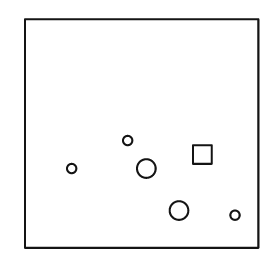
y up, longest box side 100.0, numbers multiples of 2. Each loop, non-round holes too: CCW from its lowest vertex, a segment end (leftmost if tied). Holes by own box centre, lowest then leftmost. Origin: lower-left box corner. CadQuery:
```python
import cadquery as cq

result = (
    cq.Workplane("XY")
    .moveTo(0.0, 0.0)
    .lineTo(100.0, 0.0)
    .lineTo(100.0, 98.0)
    .lineTo(0.0, 98.0)
    .close()
    .moveTo(90.0, 14.0)
    .circle(2.0)
    .moveTo(66.0, 16.0)
    .circle(4.0)
    .moveTo(20.0, 34.0)
    .circle(2.0)
    .moveTo(52.0, 34.0)
    .circle(4.0)
    .moveTo(72.0, 36.0)
    .lineTo(80.0, 36.0)
    .lineTo(80.0, 44.0)
    .lineTo(72.0, 44.0)
    .close()
    .moveTo(44.0, 46.0)
    .circle(2.0)
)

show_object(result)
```